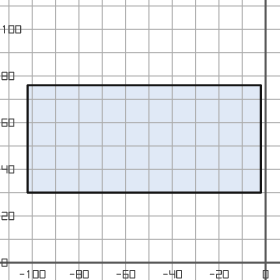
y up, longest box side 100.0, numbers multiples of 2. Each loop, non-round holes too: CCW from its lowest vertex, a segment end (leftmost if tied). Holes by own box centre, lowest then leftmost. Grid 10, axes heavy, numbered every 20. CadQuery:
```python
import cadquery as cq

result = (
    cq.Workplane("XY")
    .moveTo(-102.0, 30.0)
    .lineTo(-2.0, 30.0)
    .lineTo(-2.0, 76.0)
    .lineTo(-102.0, 76.0)
    .close()
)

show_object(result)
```